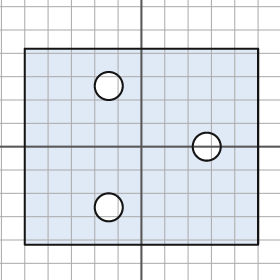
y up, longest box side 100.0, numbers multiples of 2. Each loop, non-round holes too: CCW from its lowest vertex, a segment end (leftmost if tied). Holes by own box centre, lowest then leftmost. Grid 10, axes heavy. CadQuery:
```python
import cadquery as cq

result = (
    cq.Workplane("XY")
    .moveTo(-50.0, -42.0)
    .lineTo(50.0, -42.0)
    .lineTo(50.0, 42.0)
    .lineTo(-50.0, 42.0)
    .close()
    .moveTo(-14.0, -26.0)
    .circle(6.0)
    .moveTo(28.0, 0.0)
    .circle(6.0)
    .moveTo(-14.0, 26.0)
    .circle(6.0)
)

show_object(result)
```